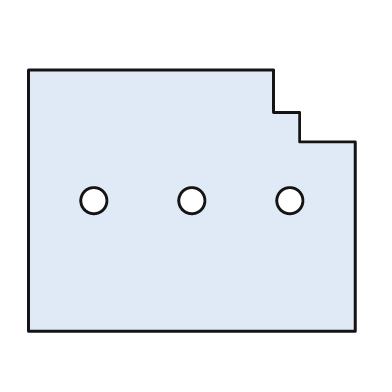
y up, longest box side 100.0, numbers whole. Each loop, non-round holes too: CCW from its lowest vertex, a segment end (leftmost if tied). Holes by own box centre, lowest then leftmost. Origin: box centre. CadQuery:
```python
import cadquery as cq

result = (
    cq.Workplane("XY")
    .moveTo(-50.0, -40.0)
    .lineTo(50.0, -40.0)
    .lineTo(50.0, 18.0)
    .lineTo(33.0, 18.0)
    .lineTo(33.0, 27.0)
    .lineTo(25.0, 27.0)
    .lineTo(25.0, 40.0)
    .lineTo(-50.0, 40.0)
    .close()
    .moveTo(-30.0, 0.0)
    .circle(4.0)
    .moveTo(0.0, 0.0)
    .circle(4.0)
    .moveTo(30.0, 0.0)
    .circle(4.0)
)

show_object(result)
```